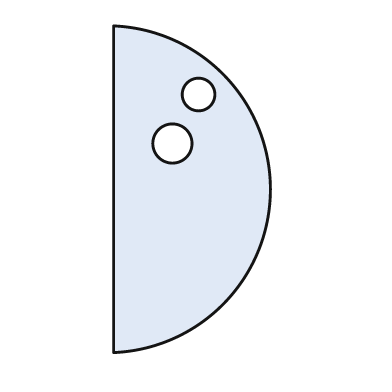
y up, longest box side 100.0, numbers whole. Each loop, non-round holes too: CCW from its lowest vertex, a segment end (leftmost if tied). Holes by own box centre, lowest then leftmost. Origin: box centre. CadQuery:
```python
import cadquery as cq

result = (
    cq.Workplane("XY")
    .moveTo(-24.0, -50.0)
    .threePointArc((24.0, 0.0), (-24.0, 50.0))
    .close()
    .moveTo(-6.0, 14.0)
    .circle(6.0)
    .moveTo(2.0, 29.0)
    .circle(5.0)
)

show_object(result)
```